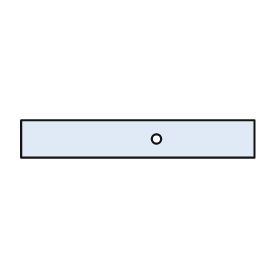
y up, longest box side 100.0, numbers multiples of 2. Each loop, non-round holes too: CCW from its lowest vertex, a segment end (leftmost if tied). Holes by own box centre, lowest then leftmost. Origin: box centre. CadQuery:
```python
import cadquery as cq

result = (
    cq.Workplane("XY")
    .moveTo(-50.0, -8.0)
    .lineTo(50.0, -8.0)
    .lineTo(50.0, 8.0)
    .lineTo(-50.0, 8.0)
    .close()
    .moveTo(8.0, 0.0)
    .circle(2.0)
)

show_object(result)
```